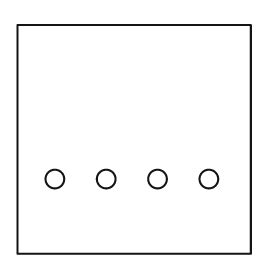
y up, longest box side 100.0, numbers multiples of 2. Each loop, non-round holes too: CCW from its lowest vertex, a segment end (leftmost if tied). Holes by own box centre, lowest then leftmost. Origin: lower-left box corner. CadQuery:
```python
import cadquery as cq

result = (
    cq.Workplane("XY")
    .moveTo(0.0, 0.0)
    .lineTo(100.0, 0.0)
    .lineTo(100.0, 98.0)
    .lineTo(0.0, 98.0)
    .close()
    .moveTo(16.0, 32.0)
    .circle(4.0)
    .moveTo(38.0, 32.0)
    .circle(4.0)
    .moveTo(60.0, 32.0)
    .circle(4.0)
    .moveTo(82.0, 32.0)
    .circle(4.0)
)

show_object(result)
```